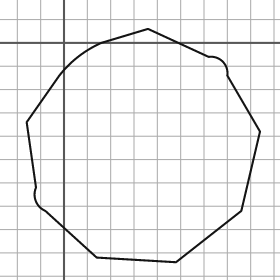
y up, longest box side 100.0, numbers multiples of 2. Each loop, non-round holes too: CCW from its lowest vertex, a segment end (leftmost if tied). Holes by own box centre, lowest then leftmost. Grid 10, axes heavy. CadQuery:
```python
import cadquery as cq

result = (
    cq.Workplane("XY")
    .moveTo(48.0, -94.0)
    .lineTo(76.0, -72.0)
    .lineTo(84.0, -38.0)
    .lineTo(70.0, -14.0)
    .threePointArc((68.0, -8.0), (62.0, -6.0))
    .lineTo(36.0, 6.0)
    .lineTo(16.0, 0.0)
    .threePointArc((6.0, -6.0), (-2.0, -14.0))
    .lineTo(-16.0, -34.0)
    .lineTo(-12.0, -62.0)
    .threePointArc((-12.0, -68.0), (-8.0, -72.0))
    .lineTo(14.0, -92.0)
    .close()
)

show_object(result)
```